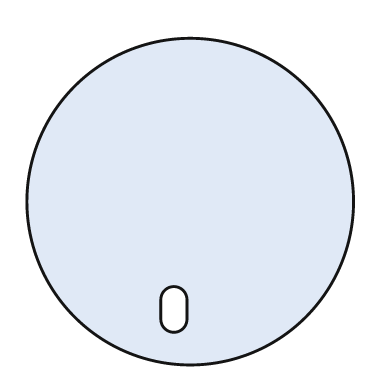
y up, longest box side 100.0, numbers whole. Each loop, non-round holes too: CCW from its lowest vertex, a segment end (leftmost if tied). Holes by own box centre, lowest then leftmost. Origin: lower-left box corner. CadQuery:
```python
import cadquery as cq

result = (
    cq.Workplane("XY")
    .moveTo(50.0, 50.0)
    .circle(50.0)
    .moveTo(41.0, 14.0)
    .threePointArc((45.0, 10.0), (49.0, 14.0))
    .lineTo(49.0, 20.0)
    .threePointArc((45.0, 24.0), (41.0, 20.0))
    .close()
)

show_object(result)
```